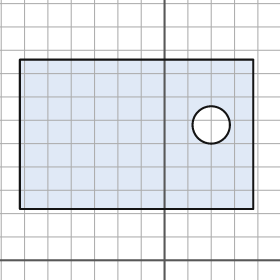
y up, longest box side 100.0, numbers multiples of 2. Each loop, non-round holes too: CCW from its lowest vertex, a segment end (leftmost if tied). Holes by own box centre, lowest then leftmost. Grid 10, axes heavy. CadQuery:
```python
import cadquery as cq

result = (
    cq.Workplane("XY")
    .moveTo(-62.0, 22.0)
    .lineTo(38.0, 22.0)
    .lineTo(38.0, 86.0)
    .lineTo(-62.0, 86.0)
    .close()
    .moveTo(20.0, 58.0)
    .circle(8.0)
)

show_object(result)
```